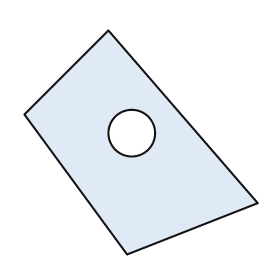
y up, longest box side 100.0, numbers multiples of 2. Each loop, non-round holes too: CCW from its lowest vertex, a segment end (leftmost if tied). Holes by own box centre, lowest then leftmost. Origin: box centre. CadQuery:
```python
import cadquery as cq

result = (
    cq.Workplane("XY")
    .moveTo(-6.0, -48.0)
    .lineTo(50.0, -26.0)
    .lineTo(-14.0, 48.0)
    .lineTo(-50.0, 12.0)
    .close()
    .moveTo(-4.0, 4.0)
    .circle(10.0)
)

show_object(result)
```